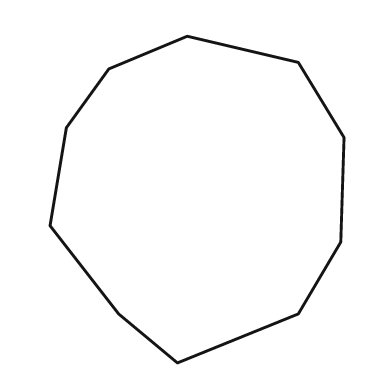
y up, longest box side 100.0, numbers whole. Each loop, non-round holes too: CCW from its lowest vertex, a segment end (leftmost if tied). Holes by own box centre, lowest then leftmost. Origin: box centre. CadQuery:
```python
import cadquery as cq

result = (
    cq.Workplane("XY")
    .moveTo(-6.0, -50.0)
    .lineTo(31.0, -35.0)
    .lineTo(44.0, -13.0)
    .lineTo(45.0, 19.0)
    .lineTo(31.0, 42.0)
    .lineTo(-3.0, 50.0)
    .lineTo(-27.0, 40.0)
    .lineTo(-40.0, 22.0)
    .lineTo(-45.0, -8.0)
    .lineTo(-24.0, -35.0)
    .close()
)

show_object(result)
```